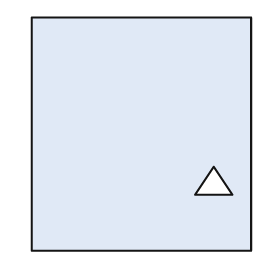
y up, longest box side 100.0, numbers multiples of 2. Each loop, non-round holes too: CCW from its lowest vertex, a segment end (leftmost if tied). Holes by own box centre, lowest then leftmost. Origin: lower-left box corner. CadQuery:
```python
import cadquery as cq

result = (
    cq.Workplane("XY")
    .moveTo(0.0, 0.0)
    .lineTo(94.0, 0.0)
    .lineTo(94.0, 100.0)
    .lineTo(0.0, 100.0)
    .close()
    .moveTo(70.0, 24.0)
    .lineTo(86.0, 24.0)
    .lineTo(78.0, 36.0)
    .close()
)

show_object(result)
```